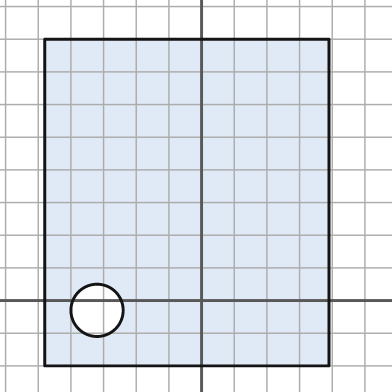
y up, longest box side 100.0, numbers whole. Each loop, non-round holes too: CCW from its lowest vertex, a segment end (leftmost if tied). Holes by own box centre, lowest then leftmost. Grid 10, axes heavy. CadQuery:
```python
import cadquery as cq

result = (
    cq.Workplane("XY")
    .moveTo(-48.0, -20.0)
    .lineTo(39.0, -20.0)
    .lineTo(39.0, 80.0)
    .lineTo(-48.0, 80.0)
    .close()
    .moveTo(-32.0, -3.0)
    .circle(8.0)
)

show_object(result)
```